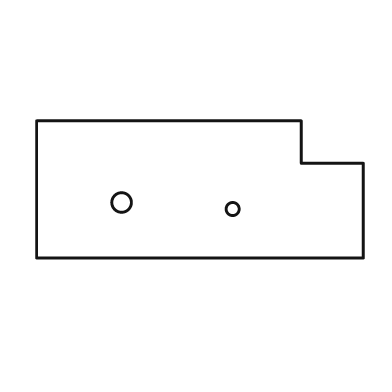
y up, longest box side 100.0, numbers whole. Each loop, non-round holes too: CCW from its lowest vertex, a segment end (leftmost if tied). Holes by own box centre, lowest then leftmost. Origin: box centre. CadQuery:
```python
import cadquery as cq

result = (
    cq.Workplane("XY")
    .moveTo(-50.0, -21.0)
    .lineTo(50.0, -21.0)
    .lineTo(50.0, 8.0)
    .lineTo(31.0, 8.0)
    .lineTo(31.0, 21.0)
    .lineTo(-50.0, 21.0)
    .close()
    .moveTo(10.0, -6.0)
    .circle(2.0)
    .moveTo(-24.0, -4.0)
    .circle(3.0)
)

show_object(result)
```